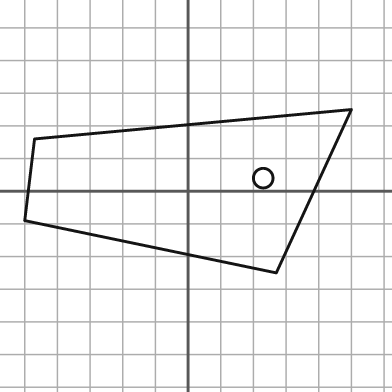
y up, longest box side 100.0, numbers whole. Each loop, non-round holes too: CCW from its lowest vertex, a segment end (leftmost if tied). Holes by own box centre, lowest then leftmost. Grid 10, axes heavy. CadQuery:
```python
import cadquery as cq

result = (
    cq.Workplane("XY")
    .moveTo(27.0, -25.0)
    .lineTo(50.0, 25.0)
    .lineTo(-47.0, 16.0)
    .lineTo(-50.0, -9.0)
    .close()
    .moveTo(23.0, 4.0)
    .circle(3.0)
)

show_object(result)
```